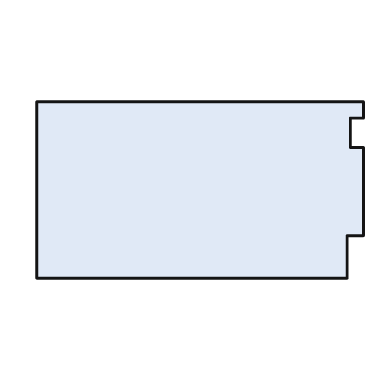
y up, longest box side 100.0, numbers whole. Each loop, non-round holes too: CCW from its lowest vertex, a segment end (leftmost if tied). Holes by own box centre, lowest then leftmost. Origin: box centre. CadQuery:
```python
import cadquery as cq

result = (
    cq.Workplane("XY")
    .moveTo(-50.0, -27.0)
    .lineTo(45.0, -27.0)
    .lineTo(45.0, -14.0)
    .lineTo(50.0, -14.0)
    .lineTo(50.0, 13.0)
    .lineTo(46.0, 13.0)
    .lineTo(46.0, 22.0)
    .lineTo(50.0, 22.0)
    .lineTo(50.0, 27.0)
    .lineTo(-50.0, 27.0)
    .close()
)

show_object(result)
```